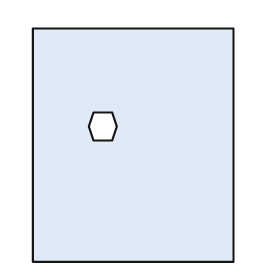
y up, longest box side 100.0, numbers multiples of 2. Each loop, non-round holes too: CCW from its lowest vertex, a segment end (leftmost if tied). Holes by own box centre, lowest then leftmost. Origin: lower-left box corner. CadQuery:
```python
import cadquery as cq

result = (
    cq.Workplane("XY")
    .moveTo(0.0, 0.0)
    .lineTo(86.0, 0.0)
    .lineTo(86.0, 100.0)
    .lineTo(0.0, 100.0)
    .close()
    .moveTo(26.0, 52.0)
    .lineTo(34.0, 52.0)
    .lineTo(36.0, 58.0)
    .lineTo(34.0, 64.0)
    .lineTo(26.0, 64.0)
    .lineTo(24.0, 58.0)
    .close()
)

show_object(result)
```